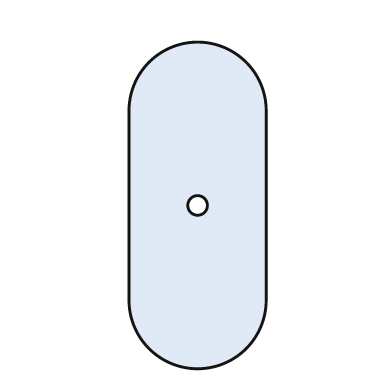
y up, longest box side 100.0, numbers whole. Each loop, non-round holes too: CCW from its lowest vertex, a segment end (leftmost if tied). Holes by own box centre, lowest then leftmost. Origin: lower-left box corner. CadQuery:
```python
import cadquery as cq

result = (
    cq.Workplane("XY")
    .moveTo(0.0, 21.0)
    .threePointArc((21.0, 0.0), (42.0, 21.0))
    .lineTo(42.0, 79.0)
    .threePointArc((21.0, 100.0), (0.0, 79.0))
    .close()
    .moveTo(21.0, 50.0)
    .circle(3.0)
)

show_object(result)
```